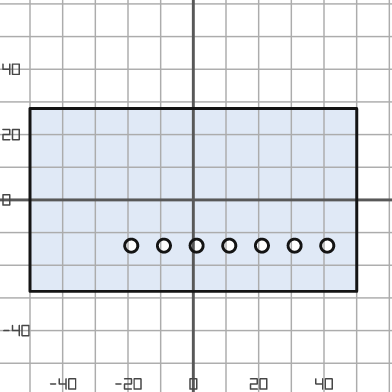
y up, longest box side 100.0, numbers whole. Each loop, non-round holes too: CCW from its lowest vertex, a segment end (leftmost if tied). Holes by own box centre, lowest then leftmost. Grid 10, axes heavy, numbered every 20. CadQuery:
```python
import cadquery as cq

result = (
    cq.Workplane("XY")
    .moveTo(-50.0, -28.0)
    .lineTo(50.0, -28.0)
    .lineTo(50.0, 28.0)
    .lineTo(-50.0, 28.0)
    .close()
    .moveTo(-19.0, -14.0)
    .circle(2.0)
    .moveTo(-9.0, -14.0)
    .circle(2.0)
    .moveTo(1.0, -14.0)
    .circle(2.0)
    .moveTo(11.0, -14.0)
    .circle(2.0)
    .moveTo(21.0, -14.0)
    .circle(2.0)
    .moveTo(31.0, -14.0)
    .circle(2.0)
    .moveTo(41.0, -14.0)
    .circle(2.0)
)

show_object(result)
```